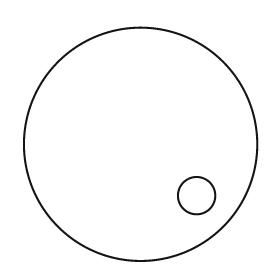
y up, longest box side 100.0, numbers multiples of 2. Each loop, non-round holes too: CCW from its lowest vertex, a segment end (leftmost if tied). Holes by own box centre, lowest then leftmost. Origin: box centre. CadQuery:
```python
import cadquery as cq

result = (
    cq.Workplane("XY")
    .moveTo(0.0, 0.0)
    .circle(50.0)
    .moveTo(24.0, -22.0)
    .circle(8.0)
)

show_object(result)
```